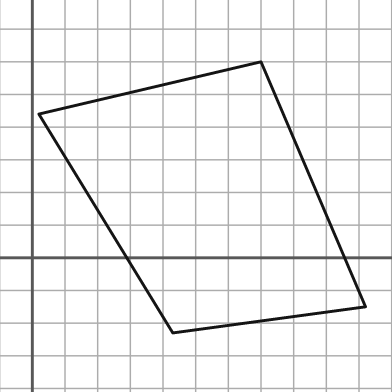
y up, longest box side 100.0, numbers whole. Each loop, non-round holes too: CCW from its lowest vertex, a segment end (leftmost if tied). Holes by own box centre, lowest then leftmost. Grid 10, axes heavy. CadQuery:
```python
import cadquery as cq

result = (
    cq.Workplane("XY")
    .moveTo(43.0, -23.0)
    .lineTo(102.0, -15.0)
    .lineTo(70.0, 60.0)
    .lineTo(2.0, 44.0)
    .close()
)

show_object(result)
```